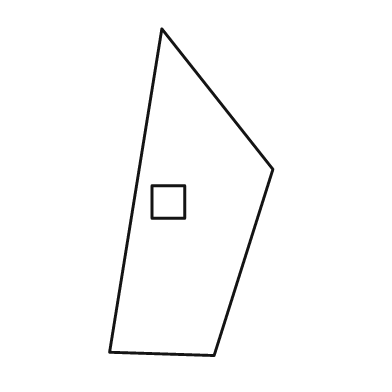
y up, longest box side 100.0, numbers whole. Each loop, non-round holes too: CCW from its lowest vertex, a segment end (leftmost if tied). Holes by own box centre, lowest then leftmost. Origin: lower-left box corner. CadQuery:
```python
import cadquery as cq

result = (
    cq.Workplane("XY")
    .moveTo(32.0, 0.0)
    .lineTo(50.0, 57.0)
    .lineTo(16.0, 100.0)
    .lineTo(0.0, 1.0)
    .close()
    .moveTo(13.0, 42.0)
    .lineTo(23.0, 42.0)
    .lineTo(23.0, 52.0)
    .lineTo(13.0, 52.0)
    .close()
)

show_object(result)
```